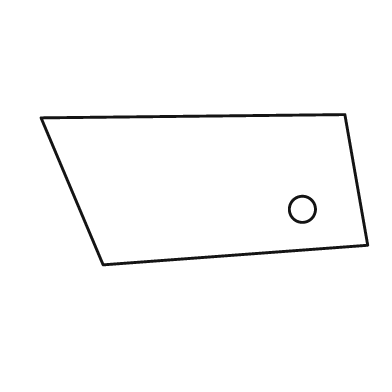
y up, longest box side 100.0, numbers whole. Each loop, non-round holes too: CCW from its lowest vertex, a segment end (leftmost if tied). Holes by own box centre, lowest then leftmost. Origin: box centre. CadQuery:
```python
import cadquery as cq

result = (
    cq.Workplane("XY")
    .moveTo(-31.0, -23.0)
    .lineTo(50.0, -17.0)
    .lineTo(43.0, 23.0)
    .lineTo(-50.0, 22.0)
    .close()
    .moveTo(30.0, -6.0)
    .circle(4.0)
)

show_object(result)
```